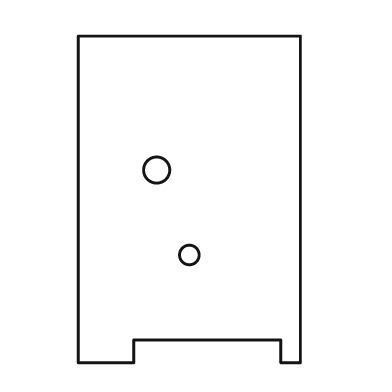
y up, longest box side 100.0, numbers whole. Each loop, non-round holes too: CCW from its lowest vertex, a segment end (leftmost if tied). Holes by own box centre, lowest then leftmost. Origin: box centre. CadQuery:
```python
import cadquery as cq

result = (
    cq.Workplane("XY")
    .moveTo(-34.0, -50.0)
    .lineTo(-17.0, -50.0)
    .lineTo(-17.0, -43.0)
    .lineTo(28.0, -43.0)
    .lineTo(28.0, -50.0)
    .lineTo(34.0, -50.0)
    .lineTo(34.0, 50.0)
    .lineTo(-34.0, 50.0)
    .close()
    .moveTo(0.0, -17.0)
    .circle(3.0)
    .moveTo(-10.0, 9.0)
    .circle(4.0)
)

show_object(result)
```